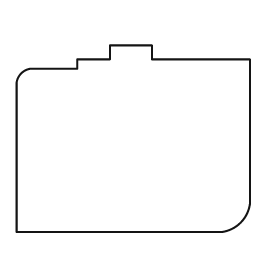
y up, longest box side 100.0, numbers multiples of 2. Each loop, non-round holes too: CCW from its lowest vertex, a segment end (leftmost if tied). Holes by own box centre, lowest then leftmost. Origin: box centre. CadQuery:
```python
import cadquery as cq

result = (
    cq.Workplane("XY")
    .moveTo(-50.0, -40.0)
    .lineTo(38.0, -40.0)
    .threePointArc((46.0, -36.0), (50.0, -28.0))
    .lineTo(50.0, 34.0)
    .lineTo(8.0, 34.0)
    .lineTo(8.0, 40.0)
    .lineTo(-10.0, 40.0)
    .lineTo(-10.0, 34.0)
    .lineTo(-24.0, 34.0)
    .lineTo(-24.0, 30.0)
    .lineTo(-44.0, 30.0)
    .threePointArc((-48.0, 28.0), (-50.0, 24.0))
    .close()
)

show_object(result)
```